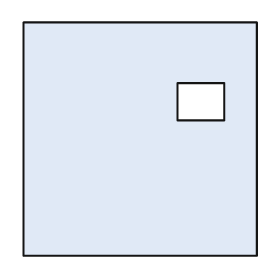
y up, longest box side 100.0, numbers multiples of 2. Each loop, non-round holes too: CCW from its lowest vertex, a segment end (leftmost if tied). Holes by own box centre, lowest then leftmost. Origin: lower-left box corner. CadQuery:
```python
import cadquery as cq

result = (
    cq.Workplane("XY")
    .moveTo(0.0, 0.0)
    .lineTo(100.0, 0.0)
    .lineTo(100.0, 100.0)
    .lineTo(0.0, 100.0)
    .close()
    .moveTo(66.0, 58.0)
    .lineTo(86.0, 58.0)
    .lineTo(86.0, 74.0)
    .lineTo(66.0, 74.0)
    .close()
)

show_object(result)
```